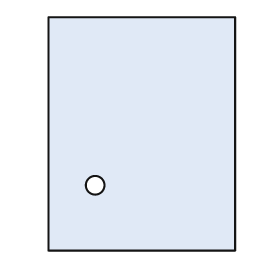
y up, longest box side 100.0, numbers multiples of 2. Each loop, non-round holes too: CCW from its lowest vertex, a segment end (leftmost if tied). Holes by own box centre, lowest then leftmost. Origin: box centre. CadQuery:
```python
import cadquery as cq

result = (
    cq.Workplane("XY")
    .moveTo(-40.0, -50.0)
    .lineTo(40.0, -50.0)
    .lineTo(40.0, 50.0)
    .lineTo(-40.0, 50.0)
    .close()
    .moveTo(-20.0, -22.0)
    .circle(4.0)
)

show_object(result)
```